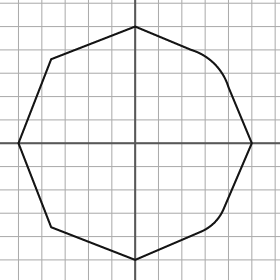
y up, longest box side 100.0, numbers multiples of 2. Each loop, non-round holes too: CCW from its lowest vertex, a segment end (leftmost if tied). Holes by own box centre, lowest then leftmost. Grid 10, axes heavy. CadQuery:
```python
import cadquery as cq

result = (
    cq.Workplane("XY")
    .moveTo(0.0, -50.0)
    .lineTo(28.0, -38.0)
    .threePointArc((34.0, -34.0), (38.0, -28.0))
    .lineTo(50.0, 0.0)
    .lineTo(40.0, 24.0)
    .threePointArc((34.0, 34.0), (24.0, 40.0))
    .lineTo(0.0, 50.0)
    .lineTo(-36.0, 36.0)
    .lineTo(-50.0, 0.0)
    .lineTo(-36.0, -36.0)
    .close()
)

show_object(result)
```